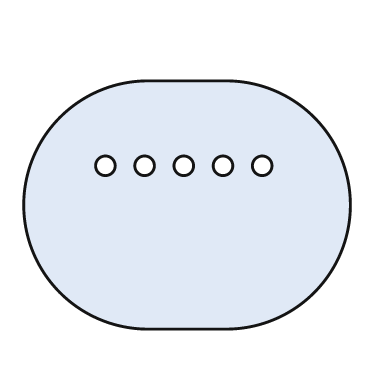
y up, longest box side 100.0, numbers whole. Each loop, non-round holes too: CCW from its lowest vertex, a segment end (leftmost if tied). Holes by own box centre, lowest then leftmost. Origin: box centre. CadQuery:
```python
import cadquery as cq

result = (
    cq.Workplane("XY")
    .moveTo(-12.0, -38.0)
    .lineTo(12.0, -38.0)
    .threePointArc((50.0, 0.0), (12.0, 38.0))
    .lineTo(-12.0, 38.0)
    .threePointArc((-50.0, 0.0), (-12.0, -38.0))
    .close()
    .moveTo(-25.0, 12.0)
    .circle(3.0)
    .moveTo(-13.0, 12.0)
    .circle(3.0)
    .moveTo(-1.0, 12.0)
    .circle(3.0)
    .moveTo(11.0, 12.0)
    .circle(3.0)
    .moveTo(23.0, 12.0)
    .circle(3.0)
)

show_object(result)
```